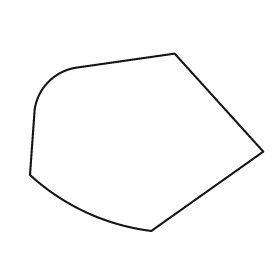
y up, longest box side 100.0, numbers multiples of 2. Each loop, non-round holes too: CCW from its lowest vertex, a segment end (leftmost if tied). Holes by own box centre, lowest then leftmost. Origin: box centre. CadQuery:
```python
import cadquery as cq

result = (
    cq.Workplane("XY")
    .moveTo(2.0, -38.0)
    .lineTo(50.0, -4.0)
    .lineTo(12.0, 38.0)
    .lineTo(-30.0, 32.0)
    .threePointArc((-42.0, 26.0), (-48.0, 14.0))
    .lineTo(-50.0, -14.0)
    .threePointArc((-26.0, -30.0), (2.0, -38.0))
    .close()
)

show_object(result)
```